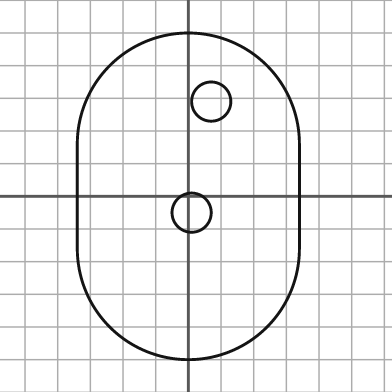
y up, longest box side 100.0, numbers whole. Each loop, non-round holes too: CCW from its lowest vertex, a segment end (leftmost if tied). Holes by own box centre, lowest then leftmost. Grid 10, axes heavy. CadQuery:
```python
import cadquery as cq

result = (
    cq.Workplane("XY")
    .moveTo(-34.0, -16.0)
    .threePointArc((0.0, -50.0), (34.0, -16.0))
    .lineTo(34.0, 16.0)
    .threePointArc((0.0, 50.0), (-34.0, 16.0))
    .close()
    .moveTo(1.0, -5.0)
    .circle(6.0)
    .moveTo(7.0, 29.0)
    .circle(6.0)
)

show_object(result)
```